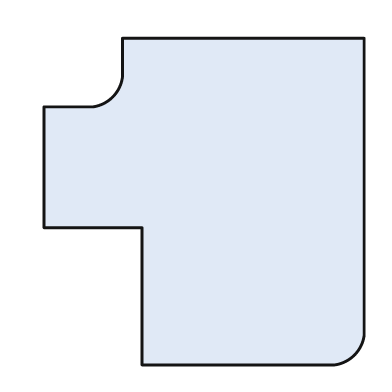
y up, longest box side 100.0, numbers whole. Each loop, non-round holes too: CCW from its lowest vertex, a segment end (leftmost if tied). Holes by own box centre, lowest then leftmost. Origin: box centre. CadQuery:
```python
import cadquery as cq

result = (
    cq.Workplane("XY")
    .moveTo(-19.0, -50.0)
    .lineTo(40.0, -50.0)
    .threePointArc((46.0, -47.0), (49.0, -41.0))
    .lineTo(49.0, 50.0)
    .lineTo(-25.0, 50.0)
    .lineTo(-25.0, 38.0)
    .threePointArc((-28.0, 32.0), (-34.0, 29.0))
    .lineTo(-49.0, 29.0)
    .lineTo(-49.0, -8.0)
    .lineTo(-19.0, -8.0)
    .close()
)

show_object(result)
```